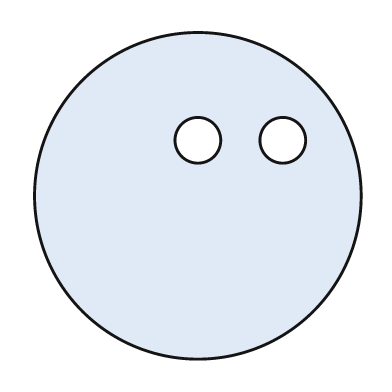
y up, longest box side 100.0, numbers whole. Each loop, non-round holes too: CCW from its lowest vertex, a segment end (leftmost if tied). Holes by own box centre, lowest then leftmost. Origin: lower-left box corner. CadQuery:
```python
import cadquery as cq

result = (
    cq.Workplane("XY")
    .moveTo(50.0, 50.0)
    .circle(50.0)
    .moveTo(50.0, 67.0)
    .circle(7.0)
    .moveTo(76.0, 67.0)
    .circle(7.0)
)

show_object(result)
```